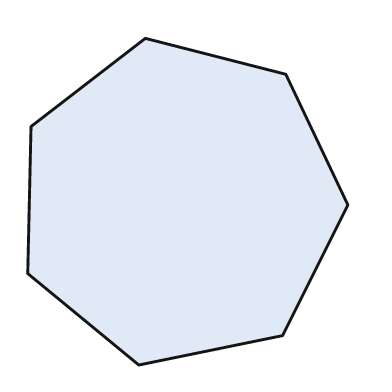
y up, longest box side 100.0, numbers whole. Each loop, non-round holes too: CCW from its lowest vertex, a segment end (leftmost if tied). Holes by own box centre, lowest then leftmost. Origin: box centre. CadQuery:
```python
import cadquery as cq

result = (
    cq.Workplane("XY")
    .moveTo(-15.0, -50.0)
    .lineTo(29.0, -41.0)
    .lineTo(49.0, -1.0)
    .lineTo(30.0, 39.0)
    .lineTo(-13.0, 50.0)
    .lineTo(-48.0, 23.0)
    .lineTo(-49.0, -22.0)
    .close()
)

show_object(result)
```